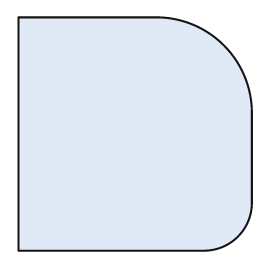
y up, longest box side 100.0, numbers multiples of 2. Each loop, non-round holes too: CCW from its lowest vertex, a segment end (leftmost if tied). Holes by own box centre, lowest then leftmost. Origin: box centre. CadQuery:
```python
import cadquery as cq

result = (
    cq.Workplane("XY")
    .moveTo(-50.0, -50.0)
    .lineTo(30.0, -50.0)
    .threePointArc((44.0, -44.0), (50.0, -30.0))
    .lineTo(50.0, 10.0)
    .threePointArc((38.0, 38.0), (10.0, 50.0))
    .lineTo(-50.0, 50.0)
    .close()
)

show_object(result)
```